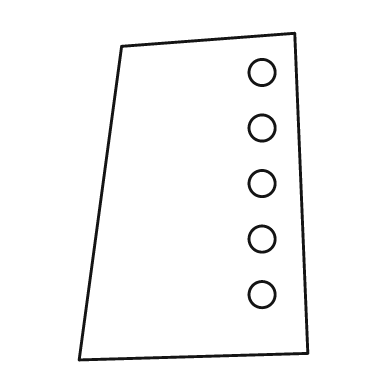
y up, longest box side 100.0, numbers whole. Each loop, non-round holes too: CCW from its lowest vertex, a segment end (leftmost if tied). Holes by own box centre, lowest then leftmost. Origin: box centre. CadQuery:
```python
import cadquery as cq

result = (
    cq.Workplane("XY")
    .moveTo(-35.0, -50.0)
    .lineTo(35.0, -48.0)
    .lineTo(31.0, 50.0)
    .lineTo(-22.0, 46.0)
    .close()
    .moveTo(21.0, -30.0)
    .circle(4.0)
    .moveTo(21.0, -13.0)
    .circle(4.0)
    .moveTo(21.0, 4.0)
    .circle(4.0)
    .moveTo(21.0, 21.0)
    .circle(4.0)
    .moveTo(21.0, 38.0)
    .circle(4.0)
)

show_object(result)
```